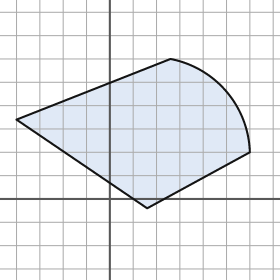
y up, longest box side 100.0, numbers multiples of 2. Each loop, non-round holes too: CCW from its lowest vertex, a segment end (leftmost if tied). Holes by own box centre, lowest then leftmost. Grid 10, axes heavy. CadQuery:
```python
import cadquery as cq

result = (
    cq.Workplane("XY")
    .moveTo(16.0, -4.0)
    .lineTo(60.0, 20.0)
    .threePointArc((50.0, 46.0), (26.0, 60.0))
    .lineTo(-40.0, 34.0)
    .close()
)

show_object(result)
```